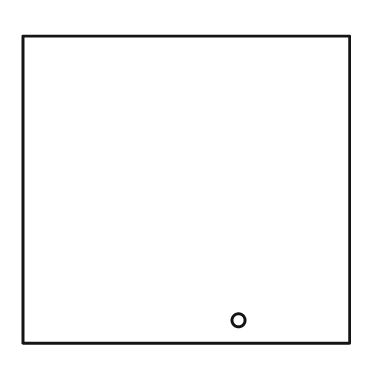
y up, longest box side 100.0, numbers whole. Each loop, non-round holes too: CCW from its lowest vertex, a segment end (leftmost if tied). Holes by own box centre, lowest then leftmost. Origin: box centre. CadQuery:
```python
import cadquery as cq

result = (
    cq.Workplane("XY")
    .moveTo(-50.0, -47.0)
    .lineTo(50.0, -47.0)
    .lineTo(50.0, 47.0)
    .lineTo(-50.0, 47.0)
    .close()
    .moveTo(16.0, -40.0)
    .circle(2.0)
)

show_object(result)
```